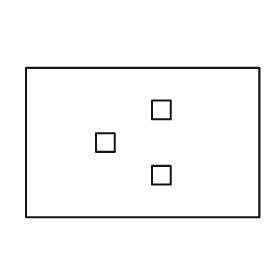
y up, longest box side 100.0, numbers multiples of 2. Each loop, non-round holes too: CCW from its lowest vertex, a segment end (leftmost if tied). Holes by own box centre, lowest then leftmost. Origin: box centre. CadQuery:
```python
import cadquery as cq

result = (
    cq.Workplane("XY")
    .moveTo(-50.0, -32.0)
    .lineTo(50.0, -32.0)
    .lineTo(50.0, 32.0)
    .lineTo(-50.0, 32.0)
    .close()
    .moveTo(4.0, -18.0)
    .lineTo(12.0, -18.0)
    .lineTo(12.0, -10.0)
    .lineTo(4.0, -10.0)
    .close()
    .moveTo(-20.0, -4.0)
    .lineTo(-12.0, -4.0)
    .lineTo(-12.0, 4.0)
    .lineTo(-20.0, 4.0)
    .close()
    .moveTo(4.0, 10.0)
    .lineTo(12.0, 10.0)
    .lineTo(12.0, 18.0)
    .lineTo(4.0, 18.0)
    .close()
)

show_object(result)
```